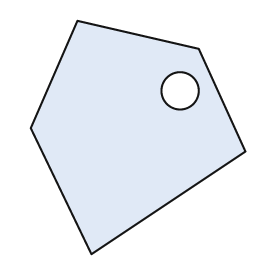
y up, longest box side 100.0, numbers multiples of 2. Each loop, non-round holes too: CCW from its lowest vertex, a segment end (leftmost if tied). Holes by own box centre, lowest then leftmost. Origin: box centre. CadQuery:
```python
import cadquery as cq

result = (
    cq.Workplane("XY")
    .moveTo(-20.0, -50.0)
    .lineTo(46.0, -6.0)
    .lineTo(26.0, 38.0)
    .lineTo(-26.0, 50.0)
    .lineTo(-46.0, 4.0)
    .close()
    .moveTo(18.0, 20.0)
    .circle(8.0)
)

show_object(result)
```